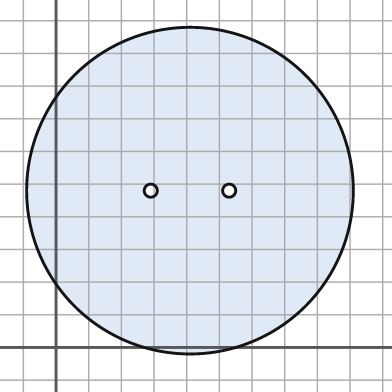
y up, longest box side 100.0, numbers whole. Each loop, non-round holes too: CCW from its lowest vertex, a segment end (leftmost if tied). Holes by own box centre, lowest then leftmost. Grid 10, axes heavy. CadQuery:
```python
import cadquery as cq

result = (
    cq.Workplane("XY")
    .moveTo(41.0, 48.0)
    .circle(50.0)
    .moveTo(29.0, 48.0)
    .circle(2.0)
    .moveTo(53.0, 48.0)
    .circle(2.0)
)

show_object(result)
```